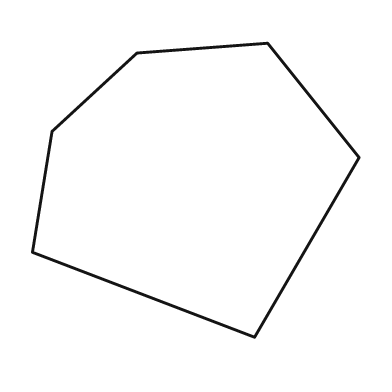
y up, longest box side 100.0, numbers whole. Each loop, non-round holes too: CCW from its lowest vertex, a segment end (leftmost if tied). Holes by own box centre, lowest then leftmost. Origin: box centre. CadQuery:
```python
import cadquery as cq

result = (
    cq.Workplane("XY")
    .moveTo(18.0, -45.0)
    .lineTo(50.0, 10.0)
    .lineTo(22.0, 45.0)
    .lineTo(-18.0, 42.0)
    .lineTo(-44.0, 18.0)
    .lineTo(-50.0, -19.0)
    .close()
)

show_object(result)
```